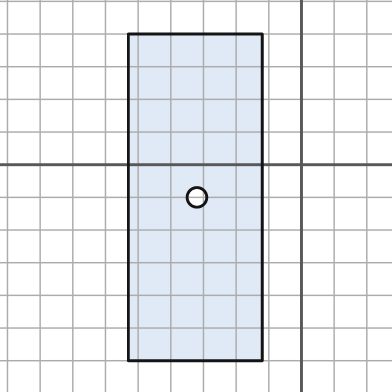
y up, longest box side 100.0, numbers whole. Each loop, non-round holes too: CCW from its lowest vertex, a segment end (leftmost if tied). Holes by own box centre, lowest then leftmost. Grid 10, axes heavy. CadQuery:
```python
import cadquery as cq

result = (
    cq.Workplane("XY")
    .moveTo(-53.0, -60.0)
    .lineTo(-12.0, -60.0)
    .lineTo(-12.0, 40.0)
    .lineTo(-53.0, 40.0)
    .close()
    .moveTo(-32.0, -10.0)
    .circle(3.0)
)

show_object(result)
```